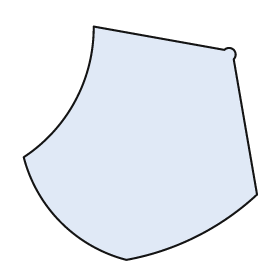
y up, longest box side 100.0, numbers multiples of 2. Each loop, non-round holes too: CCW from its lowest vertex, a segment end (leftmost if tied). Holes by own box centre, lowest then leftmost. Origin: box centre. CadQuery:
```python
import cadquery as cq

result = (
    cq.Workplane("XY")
    .moveTo(-6.0, -50.0)
    .threePointArc((24.0, -40.0), (50.0, -22.0))
    .lineTo(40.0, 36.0)
    .threePointArc((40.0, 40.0), (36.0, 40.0))
    .lineTo(-20.0, 50.0)
    .threePointArc((-28.0, 18.0), (-50.0, -6.0))
    .threePointArc((-34.0, -34.0), (-6.0, -50.0))
    .close()
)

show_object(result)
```